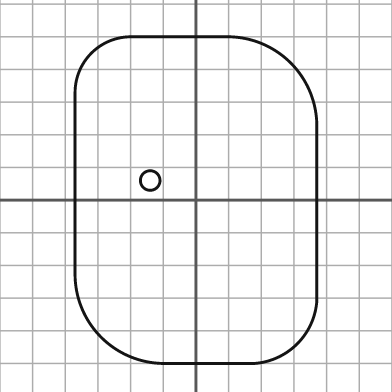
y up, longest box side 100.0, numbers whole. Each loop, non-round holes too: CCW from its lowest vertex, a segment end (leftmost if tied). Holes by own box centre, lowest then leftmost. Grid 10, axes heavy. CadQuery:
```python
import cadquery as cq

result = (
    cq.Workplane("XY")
    .moveTo(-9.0, -50.0)
    .lineTo(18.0, -50.0)
    .threePointArc((31.0, -44.0), (37.0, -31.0))
    .lineTo(37.0, 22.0)
    .threePointArc((29.0, 42.0), (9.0, 50.0))
    .lineTo(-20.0, 50.0)
    .threePointArc((-32.0, 45.0), (-37.0, 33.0))
    .lineTo(-37.0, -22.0)
    .threePointArc((-29.0, -42.0), (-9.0, -50.0))
    .close()
    .moveTo(-14.0, 6.0)
    .circle(3.0)
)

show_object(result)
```